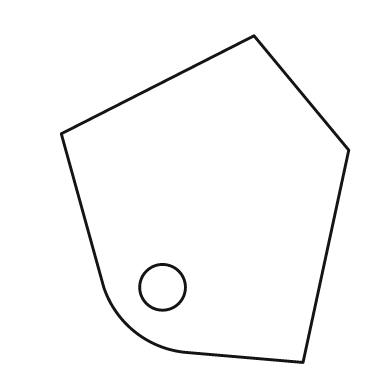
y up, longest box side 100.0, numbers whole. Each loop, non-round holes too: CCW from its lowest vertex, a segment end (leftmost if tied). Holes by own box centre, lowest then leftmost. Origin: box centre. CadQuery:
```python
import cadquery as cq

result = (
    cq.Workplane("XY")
    .moveTo(30.0, -50.0)
    .lineTo(44.0, 15.0)
    .lineTo(15.0, 50.0)
    .lineTo(-44.0, 20.0)
    .lineTo(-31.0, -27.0)
    .threePointArc((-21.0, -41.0), (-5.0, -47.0))
    .close()
    .moveTo(-13.0, -27.0)
    .circle(7.0)
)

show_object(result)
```